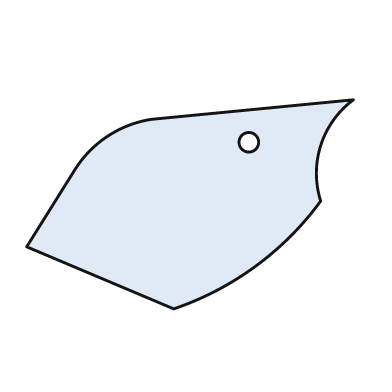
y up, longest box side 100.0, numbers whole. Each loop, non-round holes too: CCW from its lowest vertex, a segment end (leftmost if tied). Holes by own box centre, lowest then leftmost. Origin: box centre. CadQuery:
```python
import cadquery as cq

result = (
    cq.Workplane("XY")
    .moveTo(-5.0, -32.0)
    .threePointArc((20.0, -19.0), (40.0, 1.0))
    .threePointArc((40.0, 18.0), (50.0, 32.0))
    .lineTo(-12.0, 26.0)
    .threePointArc((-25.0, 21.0), (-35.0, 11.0))
    .lineTo(-50.0, -13.0)
    .close()
    .moveTo(18.0, 19.0)
    .circle(3.0)
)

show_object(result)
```